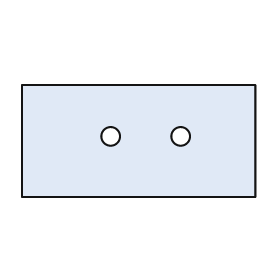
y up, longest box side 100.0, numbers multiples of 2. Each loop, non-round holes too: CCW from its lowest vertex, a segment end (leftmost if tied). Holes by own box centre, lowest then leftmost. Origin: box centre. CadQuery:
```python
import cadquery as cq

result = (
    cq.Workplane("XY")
    .moveTo(-50.0, -24.0)
    .lineTo(50.0, -24.0)
    .lineTo(50.0, 24.0)
    .lineTo(-50.0, 24.0)
    .close()
    .moveTo(-12.0, 2.0)
    .circle(4.0)
    .moveTo(18.0, 2.0)
    .circle(4.0)
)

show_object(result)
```